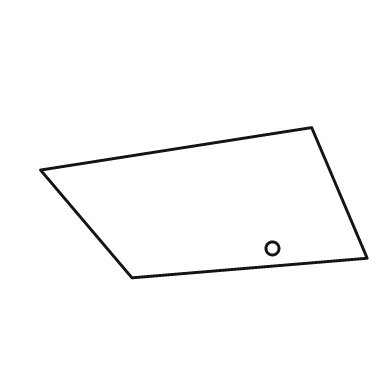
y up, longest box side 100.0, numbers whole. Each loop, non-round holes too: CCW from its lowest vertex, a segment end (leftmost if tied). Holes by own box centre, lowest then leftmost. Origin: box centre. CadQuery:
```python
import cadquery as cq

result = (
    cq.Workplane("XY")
    .moveTo(-22.0, -23.0)
    .lineTo(50.0, -17.0)
    .lineTo(33.0, 23.0)
    .lineTo(-50.0, 10.0)
    .close()
    .moveTo(21.0, -14.0)
    .circle(2.0)
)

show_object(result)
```